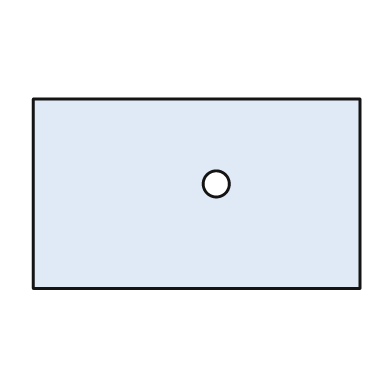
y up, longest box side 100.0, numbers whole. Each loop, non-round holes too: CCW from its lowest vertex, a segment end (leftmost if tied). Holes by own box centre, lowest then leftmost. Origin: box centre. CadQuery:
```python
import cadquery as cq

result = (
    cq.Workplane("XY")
    .moveTo(-50.0, -29.0)
    .lineTo(50.0, -29.0)
    .lineTo(50.0, 29.0)
    .lineTo(-50.0, 29.0)
    .close()
    .moveTo(6.0, 3.0)
    .circle(4.0)
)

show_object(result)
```